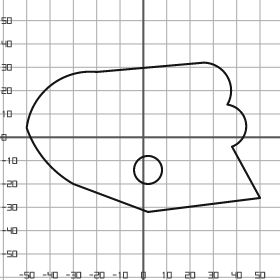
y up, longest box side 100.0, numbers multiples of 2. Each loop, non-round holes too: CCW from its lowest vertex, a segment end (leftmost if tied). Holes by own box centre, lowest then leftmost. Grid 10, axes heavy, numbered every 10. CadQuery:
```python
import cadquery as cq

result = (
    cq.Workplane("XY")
    .moveTo(2.0, -32.0)
    .lineTo(50.0, -26.0)
    .lineTo(38.0, -4.0)
    .threePointArc((44.0, 6.0), (36.0, 14.0))
    .threePointArc((36.0, 26.0), (26.0, 32.0))
    .lineTo(-20.0, 28.0)
    .threePointArc((-40.0, 22.0), (-50.0, 4.0))
    .threePointArc((-42.0, -10.0), (-30.0, -20.0))
    .close()
    .moveTo(2.0, -14.0)
    .circle(6.0)
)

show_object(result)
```